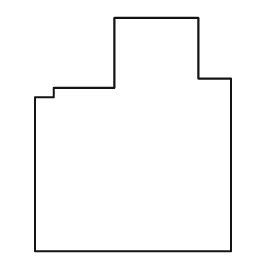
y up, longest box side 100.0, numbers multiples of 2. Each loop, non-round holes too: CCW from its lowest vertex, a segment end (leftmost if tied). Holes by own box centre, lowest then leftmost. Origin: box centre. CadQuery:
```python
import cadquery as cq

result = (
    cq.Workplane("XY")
    .moveTo(-42.0, -50.0)
    .lineTo(42.0, -50.0)
    .lineTo(42.0, 24.0)
    .lineTo(28.0, 24.0)
    .lineTo(28.0, 50.0)
    .lineTo(-8.0, 50.0)
    .lineTo(-8.0, 20.0)
    .lineTo(-34.0, 20.0)
    .lineTo(-34.0, 16.0)
    .lineTo(-42.0, 16.0)
    .close()
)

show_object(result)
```